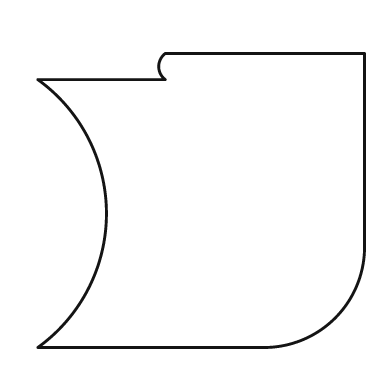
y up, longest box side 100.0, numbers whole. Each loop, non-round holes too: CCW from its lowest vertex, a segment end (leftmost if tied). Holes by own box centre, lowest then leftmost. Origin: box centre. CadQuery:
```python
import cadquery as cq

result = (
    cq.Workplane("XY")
    .moveTo(-50.0, -45.0)
    .lineTo(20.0, -45.0)
    .threePointArc((41.0, -36.0), (50.0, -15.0))
    .lineTo(50.0, 45.0)
    .lineTo(-11.0, 45.0)
    .threePointArc((-13.0, 41.0), (-11.0, 37.0))
    .lineTo(-50.0, 37.0)
    .threePointArc((-29.0, -4.0), (-50.0, -45.0))
    .close()
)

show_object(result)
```